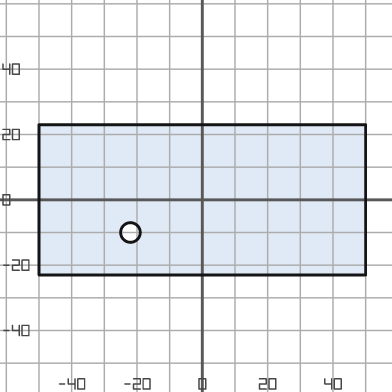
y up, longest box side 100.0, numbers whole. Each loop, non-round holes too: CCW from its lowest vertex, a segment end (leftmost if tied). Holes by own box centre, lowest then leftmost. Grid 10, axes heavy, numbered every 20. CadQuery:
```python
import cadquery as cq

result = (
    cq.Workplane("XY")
    .moveTo(-50.0, -23.0)
    .lineTo(50.0, -23.0)
    .lineTo(50.0, 23.0)
    .lineTo(-50.0, 23.0)
    .close()
    .moveTo(-22.0, -10.0)
    .circle(3.0)
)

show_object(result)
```